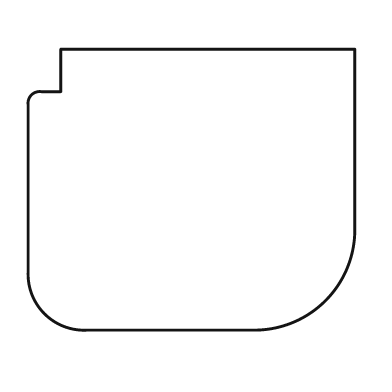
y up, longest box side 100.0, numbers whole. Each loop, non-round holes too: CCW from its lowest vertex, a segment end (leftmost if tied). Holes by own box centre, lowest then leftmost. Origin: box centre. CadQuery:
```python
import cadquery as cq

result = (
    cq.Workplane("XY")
    .moveTo(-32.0, -43.0)
    .lineTo(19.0, -43.0)
    .threePointArc((41.0, -34.0), (50.0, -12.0))
    .lineTo(50.0, 43.0)
    .lineTo(-40.0, 43.0)
    .lineTo(-40.0, 30.0)
    .lineTo(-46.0, 30.0)
    .threePointArc((-49.0, 29.0), (-50.0, 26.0))
    .lineTo(-50.0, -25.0)
    .threePointArc((-45.0, -38.0), (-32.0, -43.0))
    .close()
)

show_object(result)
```